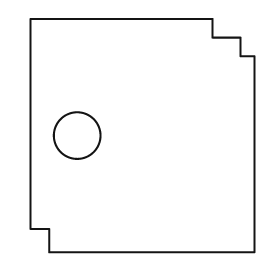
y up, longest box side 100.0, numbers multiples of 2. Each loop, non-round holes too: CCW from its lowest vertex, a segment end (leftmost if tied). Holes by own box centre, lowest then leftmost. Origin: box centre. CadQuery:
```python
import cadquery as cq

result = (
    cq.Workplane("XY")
    .moveTo(-40.0, -50.0)
    .lineTo(48.0, -50.0)
    .lineTo(48.0, 34.0)
    .lineTo(42.0, 34.0)
    .lineTo(42.0, 42.0)
    .lineTo(30.0, 42.0)
    .lineTo(30.0, 50.0)
    .lineTo(-48.0, 50.0)
    .lineTo(-48.0, -40.0)
    .lineTo(-40.0, -40.0)
    .close()
    .moveTo(-28.0, 0.0)
    .circle(10.0)
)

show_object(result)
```